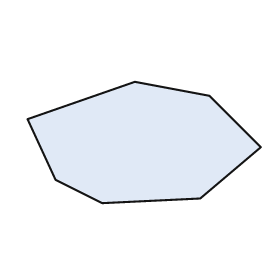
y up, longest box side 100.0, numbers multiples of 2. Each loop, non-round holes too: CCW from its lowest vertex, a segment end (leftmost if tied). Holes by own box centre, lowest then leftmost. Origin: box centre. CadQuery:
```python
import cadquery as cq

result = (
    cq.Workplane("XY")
    .moveTo(-18.0, -26.0)
    .lineTo(24.0, -24.0)
    .lineTo(50.0, -2.0)
    .lineTo(28.0, 20.0)
    .lineTo(-4.0, 26.0)
    .lineTo(-50.0, 10.0)
    .lineTo(-38.0, -16.0)
    .close()
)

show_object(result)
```